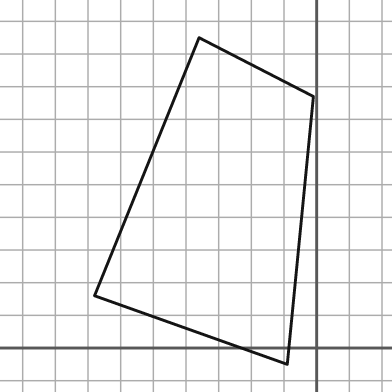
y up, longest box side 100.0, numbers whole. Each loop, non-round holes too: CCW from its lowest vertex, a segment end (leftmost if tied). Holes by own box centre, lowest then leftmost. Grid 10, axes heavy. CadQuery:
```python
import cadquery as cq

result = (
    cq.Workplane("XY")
    .moveTo(-9.0, -5.0)
    .lineTo(-1.0, 77.0)
    .lineTo(-36.0, 95.0)
    .lineTo(-68.0, 16.0)
    .close()
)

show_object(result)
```